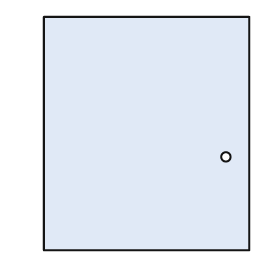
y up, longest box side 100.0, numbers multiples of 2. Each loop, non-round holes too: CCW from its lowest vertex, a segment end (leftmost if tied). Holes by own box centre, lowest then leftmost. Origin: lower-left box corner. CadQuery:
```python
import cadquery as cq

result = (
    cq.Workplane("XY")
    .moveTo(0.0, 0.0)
    .lineTo(88.0, 0.0)
    .lineTo(88.0, 100.0)
    .lineTo(0.0, 100.0)
    .close()
    .moveTo(78.0, 40.0)
    .circle(2.0)
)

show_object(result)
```